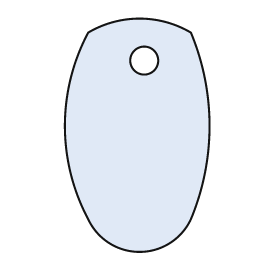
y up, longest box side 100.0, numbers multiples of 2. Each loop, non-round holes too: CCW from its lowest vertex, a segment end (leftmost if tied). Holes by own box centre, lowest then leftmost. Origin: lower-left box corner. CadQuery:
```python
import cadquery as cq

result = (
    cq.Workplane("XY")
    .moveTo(10.0, 14.0)
    .threePointArc((32.0, 0.0), (54.0, 14.0))
    .threePointArc((62.0, 54.0), (54.0, 94.0))
    .threePointArc((32.0, 100.0), (10.0, 94.0))
    .threePointArc((0.0, 54.0), (10.0, 14.0))
    .close()
    .moveTo(34.0, 82.0)
    .circle(6.0)
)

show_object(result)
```